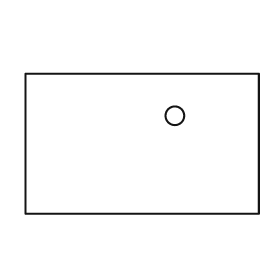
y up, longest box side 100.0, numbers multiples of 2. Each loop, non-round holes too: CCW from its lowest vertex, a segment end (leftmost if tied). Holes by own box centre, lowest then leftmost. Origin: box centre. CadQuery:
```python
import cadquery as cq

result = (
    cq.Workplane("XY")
    .moveTo(-50.0, -30.0)
    .lineTo(50.0, -30.0)
    .lineTo(50.0, 30.0)
    .lineTo(-50.0, 30.0)
    .close()
    .moveTo(14.0, 12.0)
    .circle(4.0)
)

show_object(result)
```